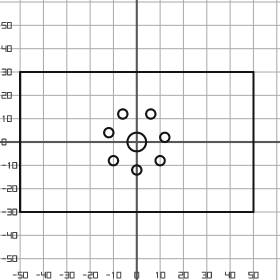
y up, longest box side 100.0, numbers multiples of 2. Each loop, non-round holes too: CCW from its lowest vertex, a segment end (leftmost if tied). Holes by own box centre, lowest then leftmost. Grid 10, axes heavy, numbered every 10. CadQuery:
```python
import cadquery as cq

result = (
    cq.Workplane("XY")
    .moveTo(-50.0, -30.0)
    .lineTo(50.0, -30.0)
    .lineTo(50.0, 30.0)
    .lineTo(-50.0, 30.0)
    .close()
    .moveTo(0.0, -12.0)
    .circle(2.0)
    .moveTo(-10.0, -8.0)
    .circle(2.0)
    .moveTo(10.0, -8.0)
    .circle(2.0)
    .moveTo(0.0, 0.0)
    .circle(4.0)
    .moveTo(12.0, 2.0)
    .circle(2.0)
    .moveTo(-12.0, 4.0)
    .circle(2.0)
    .moveTo(-6.0, 12.0)
    .circle(2.0)
    .moveTo(6.0, 12.0)
    .circle(2.0)
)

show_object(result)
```